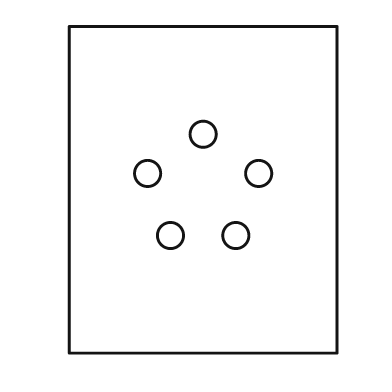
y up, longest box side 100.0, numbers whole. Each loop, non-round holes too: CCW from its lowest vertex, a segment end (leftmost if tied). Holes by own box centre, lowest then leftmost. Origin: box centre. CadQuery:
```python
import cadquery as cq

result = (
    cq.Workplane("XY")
    .moveTo(-41.0, -50.0)
    .lineTo(41.0, -50.0)
    .lineTo(41.0, 50.0)
    .lineTo(-41.0, 50.0)
    .close()
    .moveTo(-10.0, -14.0)
    .circle(4.0)
    .moveTo(10.0, -14.0)
    .circle(4.0)
    .moveTo(-17.0, 5.0)
    .circle(4.0)
    .moveTo(17.0, 5.0)
    .circle(4.0)
    .moveTo(0.0, 17.0)
    .circle(4.0)
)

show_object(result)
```